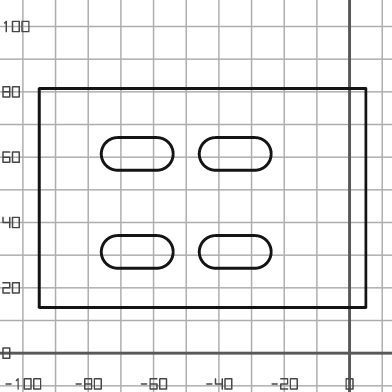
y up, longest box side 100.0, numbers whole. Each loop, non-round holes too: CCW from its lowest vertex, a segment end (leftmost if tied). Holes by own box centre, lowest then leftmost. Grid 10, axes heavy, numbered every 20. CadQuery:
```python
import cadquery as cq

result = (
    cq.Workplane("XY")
    .moveTo(-95.0, 14.0)
    .lineTo(5.0, 14.0)
    .lineTo(5.0, 81.0)
    .lineTo(-95.0, 81.0)
    .close()
    .moveTo(-71.0, 26.0)
    .lineTo(-59.0, 26.0)
    .threePointArc((-54.0, 31.0), (-59.0, 36.0))
    .lineTo(-71.0, 36.0)
    .threePointArc((-76.0, 31.0), (-71.0, 26.0))
    .close()
    .moveTo(-41.0, 26.0)
    .lineTo(-29.0, 26.0)
    .threePointArc((-24.0, 31.0), (-29.0, 36.0))
    .lineTo(-41.0, 36.0)
    .threePointArc((-46.0, 31.0), (-41.0, 26.0))
    .close()
    .moveTo(-71.0, 56.0)
    .lineTo(-59.0, 56.0)
    .threePointArc((-54.0, 61.0), (-59.0, 66.0))
    .lineTo(-71.0, 66.0)
    .threePointArc((-76.0, 61.0), (-71.0, 56.0))
    .close()
    .moveTo(-41.0, 56.0)
    .lineTo(-29.0, 56.0)
    .threePointArc((-24.0, 61.0), (-29.0, 66.0))
    .lineTo(-41.0, 66.0)
    .threePointArc((-46.0, 61.0), (-41.0, 56.0))
    .close()
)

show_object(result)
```